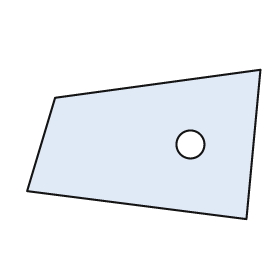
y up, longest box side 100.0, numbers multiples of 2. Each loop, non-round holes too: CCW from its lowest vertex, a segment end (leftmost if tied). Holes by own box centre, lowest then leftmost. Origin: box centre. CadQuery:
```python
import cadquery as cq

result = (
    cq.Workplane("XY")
    .moveTo(44.0, -32.0)
    .lineTo(50.0, 32.0)
    .lineTo(-38.0, 20.0)
    .lineTo(-50.0, -20.0)
    .close()
    .moveTo(20.0, 0.0)
    .circle(6.0)
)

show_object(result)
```